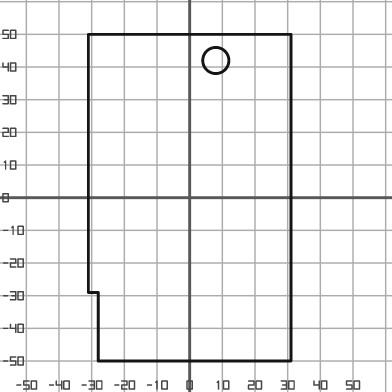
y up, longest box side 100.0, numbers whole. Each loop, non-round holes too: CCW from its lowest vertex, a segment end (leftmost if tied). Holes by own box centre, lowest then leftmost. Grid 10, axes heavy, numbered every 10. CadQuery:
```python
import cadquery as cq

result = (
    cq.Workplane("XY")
    .moveTo(-28.0, -50.0)
    .lineTo(31.0, -50.0)
    .lineTo(31.0, 50.0)
    .lineTo(-31.0, 50.0)
    .lineTo(-31.0, -29.0)
    .lineTo(-28.0, -29.0)
    .close()
    .moveTo(8.0, 42.0)
    .circle(4.0)
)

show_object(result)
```